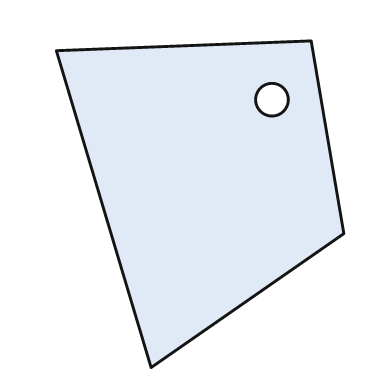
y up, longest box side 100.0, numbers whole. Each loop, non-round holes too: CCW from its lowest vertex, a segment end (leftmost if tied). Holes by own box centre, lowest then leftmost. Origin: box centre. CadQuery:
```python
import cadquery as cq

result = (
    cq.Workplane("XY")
    .moveTo(-15.0, -50.0)
    .lineTo(44.0, -9.0)
    .lineTo(34.0, 50.0)
    .lineTo(-44.0, 47.0)
    .close()
    .moveTo(22.0, 32.0)
    .circle(5.0)
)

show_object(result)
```